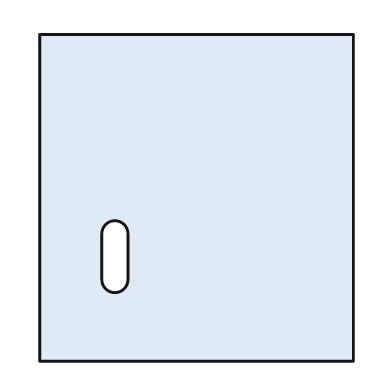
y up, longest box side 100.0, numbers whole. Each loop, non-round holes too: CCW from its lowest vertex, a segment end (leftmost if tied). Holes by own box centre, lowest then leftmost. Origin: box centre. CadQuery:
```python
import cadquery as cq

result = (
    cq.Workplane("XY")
    .moveTo(-48.0, -50.0)
    .lineTo(48.0, -50.0)
    .lineTo(48.0, 50.0)
    .lineTo(-48.0, 50.0)
    .close()
    .moveTo(-29.0, -25.0)
    .threePointArc((-25.0, -29.0), (-21.0, -25.0))
    .lineTo(-21.0, -11.0)
    .threePointArc((-25.0, -7.0), (-29.0, -11.0))
    .close()
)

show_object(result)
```